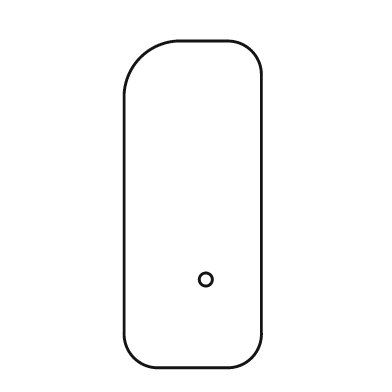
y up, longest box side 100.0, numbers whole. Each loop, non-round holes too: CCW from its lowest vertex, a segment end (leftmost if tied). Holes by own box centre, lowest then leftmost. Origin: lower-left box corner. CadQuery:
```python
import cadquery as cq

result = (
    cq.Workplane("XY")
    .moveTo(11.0, 0.0)
    .lineTo(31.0, 0.0)
    .threePointArc((39.0, 3.0), (42.0, 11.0))
    .lineTo(42.0, 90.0)
    .threePointArc((39.0, 97.0), (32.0, 100.0))
    .lineTo(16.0, 100.0)
    .threePointArc((5.0, 95.0), (0.0, 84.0))
    .lineTo(0.0, 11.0)
    .threePointArc((3.0, 3.0), (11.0, 0.0))
    .close()
    .moveTo(25.0, 27.0)
    .circle(2.0)
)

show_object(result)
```